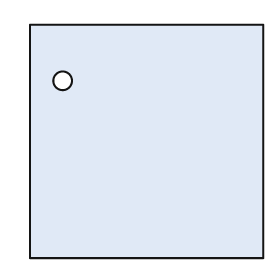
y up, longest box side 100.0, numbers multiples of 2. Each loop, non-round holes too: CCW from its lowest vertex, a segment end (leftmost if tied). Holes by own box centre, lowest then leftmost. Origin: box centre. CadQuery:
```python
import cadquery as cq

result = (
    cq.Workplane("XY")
    .moveTo(-50.0, -50.0)
    .lineTo(50.0, -50.0)
    .lineTo(50.0, 50.0)
    .lineTo(-50.0, 50.0)
    .close()
    .moveTo(-36.0, 26.0)
    .circle(4.0)
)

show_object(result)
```